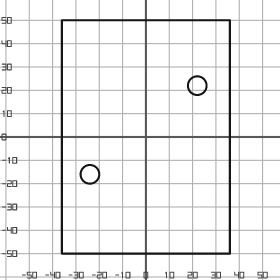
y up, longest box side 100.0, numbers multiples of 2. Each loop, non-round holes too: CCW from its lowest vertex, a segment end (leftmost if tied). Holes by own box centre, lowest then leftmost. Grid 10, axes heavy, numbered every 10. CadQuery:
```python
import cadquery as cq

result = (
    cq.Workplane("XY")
    .moveTo(-36.0, -50.0)
    .lineTo(36.0, -50.0)
    .lineTo(36.0, 50.0)
    .lineTo(-36.0, 50.0)
    .close()
    .moveTo(-24.0, -16.0)
    .circle(4.0)
    .moveTo(22.0, 22.0)
    .circle(4.0)
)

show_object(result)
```